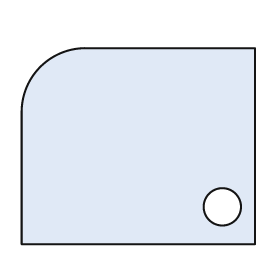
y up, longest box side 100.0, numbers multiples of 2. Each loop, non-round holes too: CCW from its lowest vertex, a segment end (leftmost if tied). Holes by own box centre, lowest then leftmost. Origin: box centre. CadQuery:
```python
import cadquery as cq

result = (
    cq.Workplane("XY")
    .moveTo(-50.0, -42.0)
    .lineTo(50.0, -42.0)
    .lineTo(50.0, 42.0)
    .lineTo(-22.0, 42.0)
    .threePointArc((-42.0, 34.0), (-50.0, 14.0))
    .close()
    .moveTo(36.0, -26.0)
    .circle(8.0)
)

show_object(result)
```